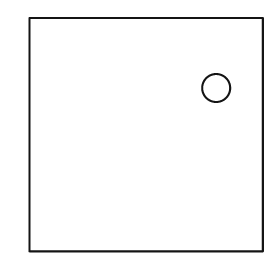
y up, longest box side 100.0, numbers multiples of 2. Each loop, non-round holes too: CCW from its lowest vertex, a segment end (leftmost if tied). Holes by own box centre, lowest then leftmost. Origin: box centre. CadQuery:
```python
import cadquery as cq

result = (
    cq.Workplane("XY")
    .moveTo(-50.0, -50.0)
    .lineTo(50.0, -50.0)
    .lineTo(50.0, 50.0)
    .lineTo(-50.0, 50.0)
    .close()
    .moveTo(30.0, 20.0)
    .circle(6.0)
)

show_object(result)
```